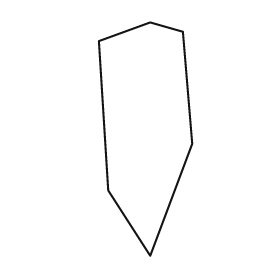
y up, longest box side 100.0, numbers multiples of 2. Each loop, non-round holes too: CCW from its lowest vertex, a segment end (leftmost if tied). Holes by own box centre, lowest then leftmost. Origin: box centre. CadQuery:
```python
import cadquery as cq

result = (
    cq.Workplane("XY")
    .moveTo(2.0, -50.0)
    .lineTo(20.0, -2.0)
    .lineTo(16.0, 46.0)
    .lineTo(2.0, 50.0)
    .lineTo(-20.0, 42.0)
    .lineTo(-16.0, -22.0)
    .close()
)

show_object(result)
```